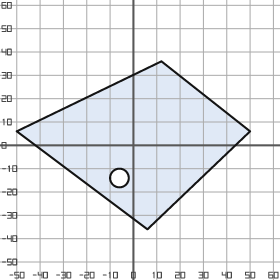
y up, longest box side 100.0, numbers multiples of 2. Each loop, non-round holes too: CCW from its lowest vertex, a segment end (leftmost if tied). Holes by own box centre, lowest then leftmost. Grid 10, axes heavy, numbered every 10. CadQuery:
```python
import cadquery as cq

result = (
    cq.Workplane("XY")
    .moveTo(6.0, -36.0)
    .lineTo(50.0, 6.0)
    .lineTo(12.0, 36.0)
    .lineTo(-50.0, 6.0)
    .close()
    .moveTo(-6.0, -14.0)
    .circle(4.0)
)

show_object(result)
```